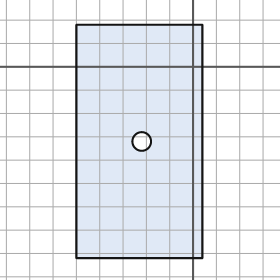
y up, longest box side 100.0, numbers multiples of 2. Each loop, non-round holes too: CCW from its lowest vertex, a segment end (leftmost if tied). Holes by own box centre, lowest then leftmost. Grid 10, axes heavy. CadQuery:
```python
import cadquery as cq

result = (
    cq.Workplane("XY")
    .moveTo(-50.0, -82.0)
    .lineTo(4.0, -82.0)
    .lineTo(4.0, 18.0)
    .lineTo(-50.0, 18.0)
    .close()
    .moveTo(-22.0, -32.0)
    .circle(4.0)
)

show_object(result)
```